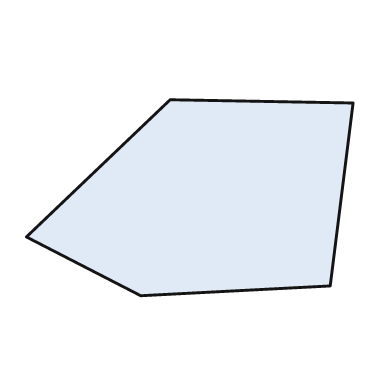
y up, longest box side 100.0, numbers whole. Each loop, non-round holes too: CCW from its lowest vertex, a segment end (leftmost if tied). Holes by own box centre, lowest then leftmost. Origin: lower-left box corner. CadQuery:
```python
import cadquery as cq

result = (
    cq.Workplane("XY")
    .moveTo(35.0, 0.0)
    .lineTo(93.0, 3.0)
    .lineTo(100.0, 59.0)
    .lineTo(44.0, 60.0)
    .lineTo(0.0, 18.0)
    .close()
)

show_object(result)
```